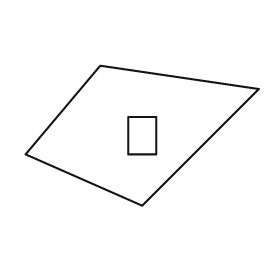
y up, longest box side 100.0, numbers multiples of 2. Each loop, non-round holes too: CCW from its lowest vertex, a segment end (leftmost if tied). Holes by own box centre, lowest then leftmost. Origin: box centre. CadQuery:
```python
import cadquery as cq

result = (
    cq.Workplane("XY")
    .moveTo(0.0, -30.0)
    .lineTo(50.0, 20.0)
    .lineTo(-18.0, 30.0)
    .lineTo(-50.0, -8.0)
    .close()
    .moveTo(-6.0, -8.0)
    .lineTo(6.0, -8.0)
    .lineTo(6.0, 8.0)
    .lineTo(-6.0, 8.0)
    .close()
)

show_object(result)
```